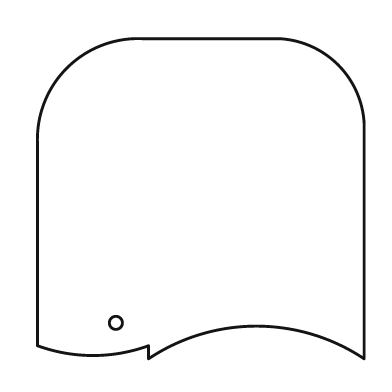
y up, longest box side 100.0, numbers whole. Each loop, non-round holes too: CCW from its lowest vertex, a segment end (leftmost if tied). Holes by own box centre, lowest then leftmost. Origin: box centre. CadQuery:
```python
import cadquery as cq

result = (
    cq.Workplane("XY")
    .moveTo(-16.0, -49.0)
    .threePointArc((17.0, -39.0), (50.0, -49.0))
    .lineTo(50.0, 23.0)
    .threePointArc((42.0, 41.0), (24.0, 49.0))
    .lineTo(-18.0, 49.0)
    .threePointArc((-41.0, 40.0), (-50.0, 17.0))
    .lineTo(-50.0, -45.0)
    .threePointArc((-33.0, -48.0), (-16.0, -45.0))
    .close()
    .moveTo(-26.0, -38.0)
    .circle(2.0)
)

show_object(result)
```